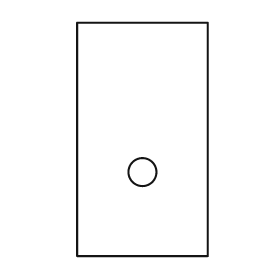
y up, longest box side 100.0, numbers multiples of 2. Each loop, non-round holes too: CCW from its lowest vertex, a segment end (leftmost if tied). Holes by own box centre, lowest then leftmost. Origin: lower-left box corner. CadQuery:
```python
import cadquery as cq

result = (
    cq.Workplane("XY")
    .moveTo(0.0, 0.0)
    .lineTo(56.0, 0.0)
    .lineTo(56.0, 100.0)
    .lineTo(0.0, 100.0)
    .close()
    .moveTo(28.0, 36.0)
    .circle(6.0)
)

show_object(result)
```